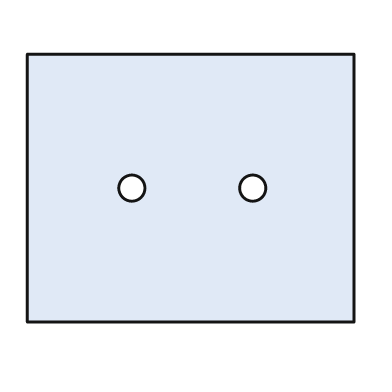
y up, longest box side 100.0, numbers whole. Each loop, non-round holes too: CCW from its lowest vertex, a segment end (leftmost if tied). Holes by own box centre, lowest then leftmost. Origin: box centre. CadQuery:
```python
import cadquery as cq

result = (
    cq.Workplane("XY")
    .moveTo(-50.0, -41.0)
    .lineTo(50.0, -41.0)
    .lineTo(50.0, 41.0)
    .lineTo(-50.0, 41.0)
    .close()
    .moveTo(-18.0, 0.0)
    .circle(4.0)
    .moveTo(19.0, 0.0)
    .circle(4.0)
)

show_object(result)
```